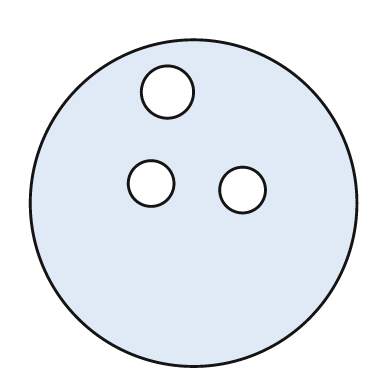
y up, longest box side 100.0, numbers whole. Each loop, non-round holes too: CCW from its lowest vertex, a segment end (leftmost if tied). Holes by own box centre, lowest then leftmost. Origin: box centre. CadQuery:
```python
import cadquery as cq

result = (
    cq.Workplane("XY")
    .moveTo(0.0, 0.0)
    .circle(50.0)
    .moveTo(15.0, 4.0)
    .circle(7.0)
    .moveTo(-13.0, 6.0)
    .circle(7.0)
    .moveTo(-8.0, 34.0)
    .circle(8.0)
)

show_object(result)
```